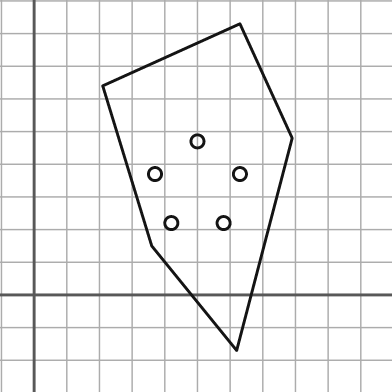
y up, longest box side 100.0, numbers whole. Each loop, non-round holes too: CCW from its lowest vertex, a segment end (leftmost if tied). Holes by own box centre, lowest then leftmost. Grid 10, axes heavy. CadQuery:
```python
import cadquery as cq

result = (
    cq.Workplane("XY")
    .moveTo(62.0, -17.0)
    .lineTo(79.0, 48.0)
    .lineTo(63.0, 83.0)
    .lineTo(21.0, 64.0)
    .lineTo(36.0, 15.0)
    .close()
    .moveTo(42.0, 22.0)
    .circle(2.0)
    .moveTo(58.0, 22.0)
    .circle(2.0)
    .moveTo(37.0, 37.0)
    .circle(2.0)
    .moveTo(63.0, 37.0)
    .circle(2.0)
    .moveTo(50.0, 47.0)
    .circle(2.0)
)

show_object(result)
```